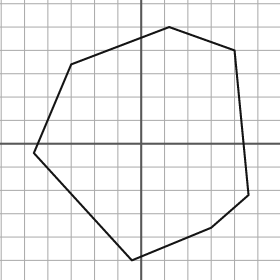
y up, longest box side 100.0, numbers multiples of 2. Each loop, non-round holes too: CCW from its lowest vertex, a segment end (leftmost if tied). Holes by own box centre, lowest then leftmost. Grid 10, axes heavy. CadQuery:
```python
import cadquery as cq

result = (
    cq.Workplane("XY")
    .moveTo(-4.0, -50.0)
    .lineTo(30.0, -36.0)
    .lineTo(46.0, -22.0)
    .lineTo(40.0, 40.0)
    .lineTo(12.0, 50.0)
    .lineTo(-30.0, 34.0)
    .lineTo(-46.0, -4.0)
    .close()
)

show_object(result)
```